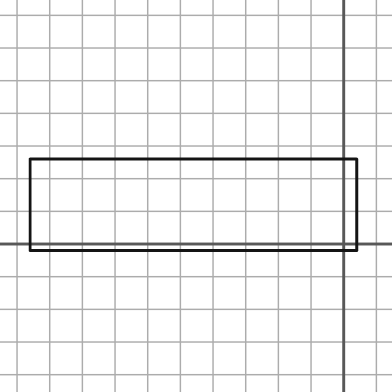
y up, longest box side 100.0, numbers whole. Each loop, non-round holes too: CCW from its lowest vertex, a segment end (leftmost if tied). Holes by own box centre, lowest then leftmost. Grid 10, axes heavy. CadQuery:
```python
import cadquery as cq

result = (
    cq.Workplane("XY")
    .moveTo(-96.0, -2.0)
    .lineTo(4.0, -2.0)
    .lineTo(4.0, 26.0)
    .lineTo(-96.0, 26.0)
    .close()
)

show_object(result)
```